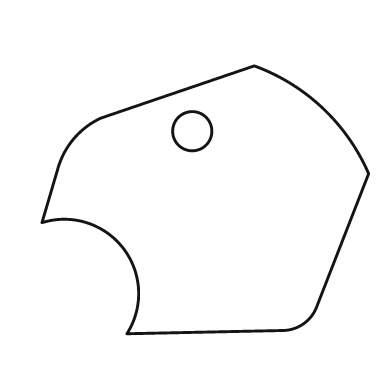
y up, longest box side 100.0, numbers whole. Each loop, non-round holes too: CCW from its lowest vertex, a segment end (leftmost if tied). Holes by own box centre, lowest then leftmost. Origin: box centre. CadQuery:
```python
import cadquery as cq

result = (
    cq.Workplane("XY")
    .moveTo(-24.0, -41.0)
    .lineTo(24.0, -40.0)
    .threePointArc((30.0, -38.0), (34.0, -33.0))
    .lineTo(50.0, 8.0)
    .threePointArc((36.0, 28.0), (15.0, 41.0))
    .lineTo(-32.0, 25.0)
    .threePointArc((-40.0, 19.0), (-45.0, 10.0))
    .lineTo(-50.0, -7.0)
    .threePointArc((-25.0, -15.0), (-24.0, -41.0))
    .close()
    .moveTo(-4.0, 21.0)
    .circle(6.0)
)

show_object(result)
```